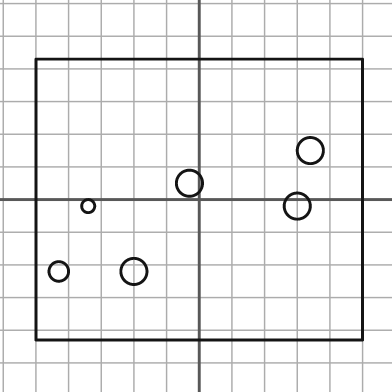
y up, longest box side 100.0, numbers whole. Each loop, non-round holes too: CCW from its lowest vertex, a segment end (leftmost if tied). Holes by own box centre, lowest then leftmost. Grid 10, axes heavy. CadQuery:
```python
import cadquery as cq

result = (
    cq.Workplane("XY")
    .moveTo(-50.0, -43.0)
    .lineTo(50.0, -43.0)
    .lineTo(50.0, 43.0)
    .lineTo(-50.0, 43.0)
    .close()
    .moveTo(-43.0, -22.0)
    .circle(3.0)
    .moveTo(-20.0, -22.0)
    .circle(4.0)
    .moveTo(-34.0, -2.0)
    .circle(2.0)
    .moveTo(30.0, -2.0)
    .circle(4.0)
    .moveTo(-3.0, 5.0)
    .circle(4.0)
    .moveTo(34.0, 15.0)
    .circle(4.0)
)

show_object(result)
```